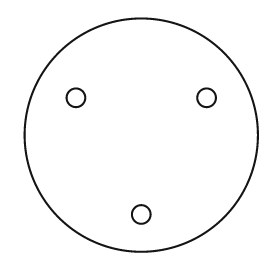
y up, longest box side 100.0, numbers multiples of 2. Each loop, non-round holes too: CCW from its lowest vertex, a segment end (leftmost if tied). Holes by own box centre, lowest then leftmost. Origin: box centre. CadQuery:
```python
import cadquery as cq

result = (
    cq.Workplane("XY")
    .moveTo(0.0, 0.0)
    .circle(50.0)
    .moveTo(0.0, -34.0)
    .circle(4.0)
    .moveTo(-28.0, 16.0)
    .circle(4.0)
    .moveTo(28.0, 16.0)
    .circle(4.0)
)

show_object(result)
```